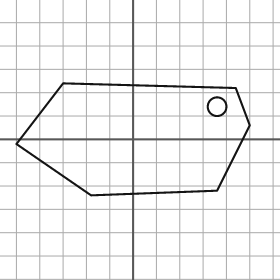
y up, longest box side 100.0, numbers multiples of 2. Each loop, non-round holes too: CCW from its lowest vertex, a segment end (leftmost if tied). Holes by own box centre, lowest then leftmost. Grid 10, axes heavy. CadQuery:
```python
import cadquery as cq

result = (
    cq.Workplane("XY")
    .moveTo(-18.0, -24.0)
    .lineTo(36.0, -22.0)
    .lineTo(50.0, 6.0)
    .lineTo(44.0, 22.0)
    .lineTo(-30.0, 24.0)
    .lineTo(-50.0, -2.0)
    .close()
    .moveTo(36.0, 14.0)
    .circle(4.0)
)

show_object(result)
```